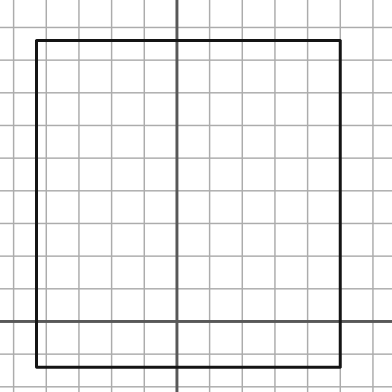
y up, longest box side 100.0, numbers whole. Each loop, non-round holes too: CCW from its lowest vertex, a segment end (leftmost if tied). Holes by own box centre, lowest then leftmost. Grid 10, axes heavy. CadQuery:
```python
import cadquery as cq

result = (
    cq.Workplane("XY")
    .moveTo(-43.0, -14.0)
    .lineTo(50.0, -14.0)
    .lineTo(50.0, 86.0)
    .lineTo(-43.0, 86.0)
    .close()
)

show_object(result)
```